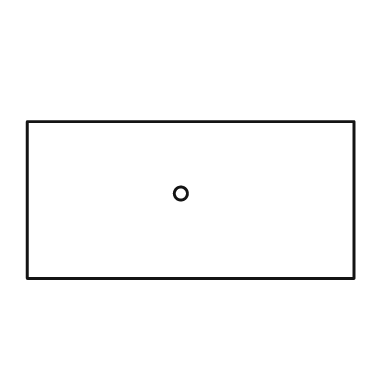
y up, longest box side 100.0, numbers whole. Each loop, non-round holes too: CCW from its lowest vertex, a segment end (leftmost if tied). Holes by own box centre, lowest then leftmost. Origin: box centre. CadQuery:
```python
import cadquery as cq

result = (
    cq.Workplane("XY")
    .moveTo(-50.0, -24.0)
    .lineTo(50.0, -24.0)
    .lineTo(50.0, 24.0)
    .lineTo(-50.0, 24.0)
    .close()
    .moveTo(-3.0, 2.0)
    .circle(2.0)
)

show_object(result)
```